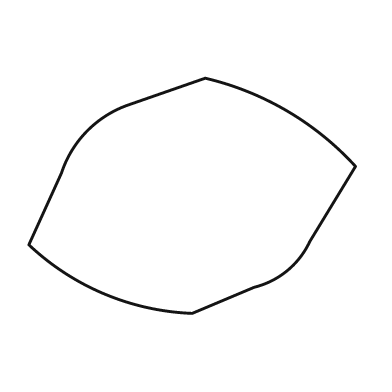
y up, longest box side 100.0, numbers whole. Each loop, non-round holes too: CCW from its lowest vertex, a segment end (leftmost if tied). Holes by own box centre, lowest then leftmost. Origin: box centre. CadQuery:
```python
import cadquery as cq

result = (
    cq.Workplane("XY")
    .moveTo(0.0, -36.0)
    .lineTo(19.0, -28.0)
    .threePointArc((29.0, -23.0), (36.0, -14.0))
    .lineTo(50.0, 9.0)
    .threePointArc((29.0, 26.0), (4.0, 36.0))
    .lineTo(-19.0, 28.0)
    .threePointArc((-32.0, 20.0), (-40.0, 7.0))
    .lineTo(-50.0, -15.0)
    .threePointArc((-27.0, -30.0), (0.0, -36.0))
    .close()
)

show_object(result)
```